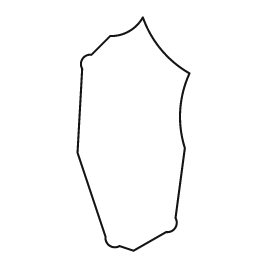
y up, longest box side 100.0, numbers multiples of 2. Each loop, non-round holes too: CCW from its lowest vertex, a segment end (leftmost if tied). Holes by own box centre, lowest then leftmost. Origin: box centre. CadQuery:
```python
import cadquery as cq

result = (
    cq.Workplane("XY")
    .moveTo(0.0, -50.0)
    .lineTo(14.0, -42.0)
    .threePointArc((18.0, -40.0), (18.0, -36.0))
    .lineTo(22.0, -6.0)
    .threePointArc((20.0, 10.0), (24.0, 26.0))
    .threePointArc((12.0, 36.0), (4.0, 50.0))
    .threePointArc((-2.0, 44.0), (-10.0, 42.0))
    .lineTo(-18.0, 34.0)
    .threePointArc((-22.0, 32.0), (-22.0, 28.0))
    .lineTo(-24.0, -8.0)
    .lineTo(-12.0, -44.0)
    .threePointArc((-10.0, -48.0), (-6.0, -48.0))
    .close()
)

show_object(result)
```